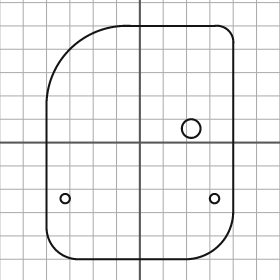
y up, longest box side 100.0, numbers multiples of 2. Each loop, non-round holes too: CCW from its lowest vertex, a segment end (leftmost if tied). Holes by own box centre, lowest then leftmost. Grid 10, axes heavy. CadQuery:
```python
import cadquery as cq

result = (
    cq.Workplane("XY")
    .moveTo(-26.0, -50.0)
    .lineTo(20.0, -50.0)
    .threePointArc((34.0, -44.0), (40.0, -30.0))
    .lineTo(40.0, 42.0)
    .threePointArc((38.0, 48.0), (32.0, 50.0))
    .lineTo(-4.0, 50.0)
    .threePointArc((-30.0, 40.0), (-40.0, 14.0))
    .lineTo(-40.0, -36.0)
    .threePointArc((-36.0, -46.0), (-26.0, -50.0))
    .close()
    .moveTo(-32.0, -24.0)
    .circle(2.0)
    .moveTo(32.0, -24.0)
    .circle(2.0)
    .moveTo(22.0, 6.0)
    .circle(4.0)
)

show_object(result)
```